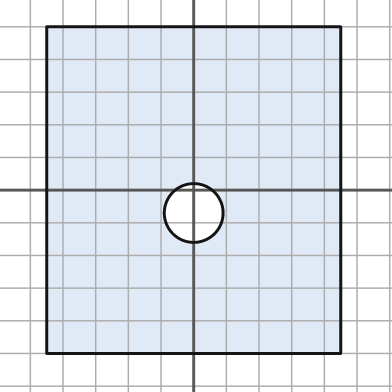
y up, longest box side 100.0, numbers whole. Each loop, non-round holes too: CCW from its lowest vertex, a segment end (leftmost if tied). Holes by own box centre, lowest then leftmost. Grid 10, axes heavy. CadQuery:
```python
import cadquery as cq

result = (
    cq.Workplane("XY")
    .moveTo(-45.0, -50.0)
    .lineTo(45.0, -50.0)
    .lineTo(45.0, 50.0)
    .lineTo(-45.0, 50.0)
    .close()
    .moveTo(0.0, -7.0)
    .circle(9.0)
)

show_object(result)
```